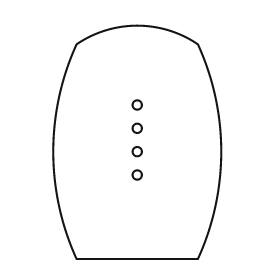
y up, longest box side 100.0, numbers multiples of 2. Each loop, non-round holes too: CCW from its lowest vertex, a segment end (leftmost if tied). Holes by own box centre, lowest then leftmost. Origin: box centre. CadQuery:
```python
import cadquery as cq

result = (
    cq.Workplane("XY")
    .moveTo(-26.0, -50.0)
    .lineTo(26.0, -50.0)
    .threePointArc((36.0, -4.0), (26.0, 42.0))
    .threePointArc((0.0, 50.0), (-26.0, 42.0))
    .threePointArc((-36.0, -4.0), (-26.0, -50.0))
    .close()
    .moveTo(0.0, -14.0)
    .circle(2.0)
    .moveTo(0.0, -4.0)
    .circle(2.0)
    .moveTo(0.0, 6.0)
    .circle(2.0)
    .moveTo(0.0, 16.0)
    .circle(2.0)
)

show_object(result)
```